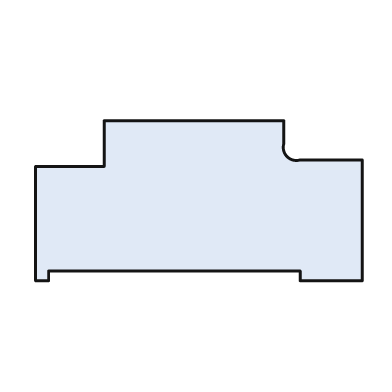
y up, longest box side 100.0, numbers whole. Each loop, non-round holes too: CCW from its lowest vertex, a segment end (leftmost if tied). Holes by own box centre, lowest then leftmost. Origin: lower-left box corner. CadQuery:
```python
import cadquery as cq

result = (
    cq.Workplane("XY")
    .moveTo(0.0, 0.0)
    .lineTo(4.0, 0.0)
    .lineTo(4.0, 3.0)
    .lineTo(81.0, 3.0)
    .lineTo(81.0, 0.0)
    .lineTo(100.0, 0.0)
    .lineTo(100.0, 37.0)
    .lineTo(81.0, 37.0)
    .threePointArc((77.0, 38.0), (76.0, 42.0))
    .lineTo(76.0, 49.0)
    .lineTo(21.0, 49.0)
    .lineTo(21.0, 35.0)
    .lineTo(0.0, 35.0)
    .close()
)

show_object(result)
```